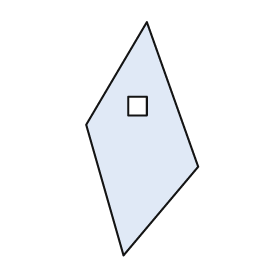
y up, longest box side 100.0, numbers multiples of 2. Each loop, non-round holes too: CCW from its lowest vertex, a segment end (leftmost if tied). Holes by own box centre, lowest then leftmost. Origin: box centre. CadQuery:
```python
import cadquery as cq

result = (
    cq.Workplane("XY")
    .moveTo(-8.0, -50.0)
    .lineTo(24.0, -12.0)
    .lineTo(2.0, 50.0)
    .lineTo(-24.0, 6.0)
    .close()
    .moveTo(-6.0, 10.0)
    .lineTo(2.0, 10.0)
    .lineTo(2.0, 18.0)
    .lineTo(-6.0, 18.0)
    .close()
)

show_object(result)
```